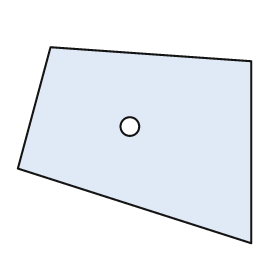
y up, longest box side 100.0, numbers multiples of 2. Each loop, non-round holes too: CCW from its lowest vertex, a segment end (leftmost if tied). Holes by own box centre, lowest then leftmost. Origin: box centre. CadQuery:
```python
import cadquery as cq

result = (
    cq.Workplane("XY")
    .moveTo(50.0, -42.0)
    .lineTo(50.0, 36.0)
    .lineTo(-36.0, 42.0)
    .lineTo(-50.0, -10.0)
    .close()
    .moveTo(-2.0, 8.0)
    .circle(4.0)
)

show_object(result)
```